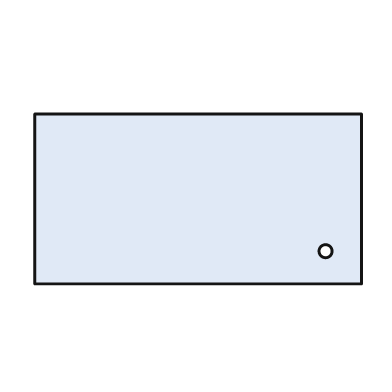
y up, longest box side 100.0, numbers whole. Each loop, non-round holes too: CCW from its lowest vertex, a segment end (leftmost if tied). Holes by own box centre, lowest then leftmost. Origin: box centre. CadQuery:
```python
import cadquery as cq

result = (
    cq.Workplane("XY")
    .moveTo(-50.0, -26.0)
    .lineTo(50.0, -26.0)
    .lineTo(50.0, 26.0)
    .lineTo(-50.0, 26.0)
    .close()
    .moveTo(39.0, -16.0)
    .circle(2.0)
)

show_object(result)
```